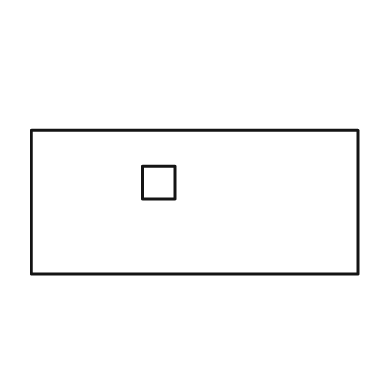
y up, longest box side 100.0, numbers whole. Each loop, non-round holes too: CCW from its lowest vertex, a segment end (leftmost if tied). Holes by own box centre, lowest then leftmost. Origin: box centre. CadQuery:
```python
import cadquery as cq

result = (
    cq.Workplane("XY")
    .moveTo(-50.0, -22.0)
    .lineTo(50.0, -22.0)
    .lineTo(50.0, 22.0)
    .lineTo(-50.0, 22.0)
    .close()
    .moveTo(-16.0, 1.0)
    .lineTo(-6.0, 1.0)
    .lineTo(-6.0, 11.0)
    .lineTo(-16.0, 11.0)
    .close()
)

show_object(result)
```